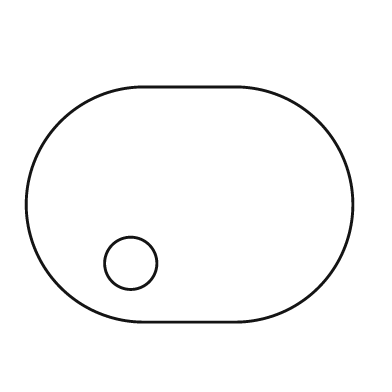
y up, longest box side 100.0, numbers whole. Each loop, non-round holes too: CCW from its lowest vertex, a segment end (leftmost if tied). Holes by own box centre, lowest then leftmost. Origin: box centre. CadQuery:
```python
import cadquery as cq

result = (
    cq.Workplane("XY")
    .moveTo(-14.0, -36.0)
    .lineTo(14.0, -36.0)
    .threePointArc((50.0, 0.0), (14.0, 36.0))
    .lineTo(-14.0, 36.0)
    .threePointArc((-50.0, 0.0), (-14.0, -36.0))
    .close()
    .moveTo(-18.0, -18.0)
    .circle(8.0)
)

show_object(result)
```